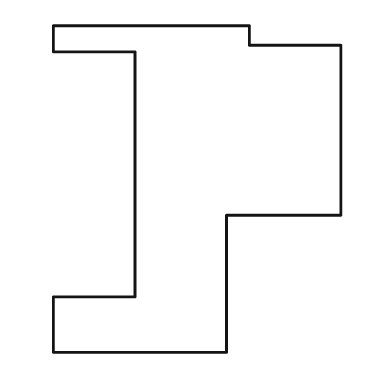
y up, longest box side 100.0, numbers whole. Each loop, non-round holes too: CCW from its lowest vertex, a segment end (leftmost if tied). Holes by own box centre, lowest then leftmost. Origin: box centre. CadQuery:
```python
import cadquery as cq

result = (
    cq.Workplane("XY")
    .moveTo(-44.0, -50.0)
    .lineTo(9.0, -50.0)
    .lineTo(9.0, -8.0)
    .lineTo(44.0, -8.0)
    .lineTo(44.0, 44.0)
    .lineTo(16.0, 44.0)
    .lineTo(16.0, 50.0)
    .lineTo(-44.0, 50.0)
    .lineTo(-44.0, 42.0)
    .lineTo(-19.0, 42.0)
    .lineTo(-19.0, -33.0)
    .lineTo(-44.0, -33.0)
    .close()
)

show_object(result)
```